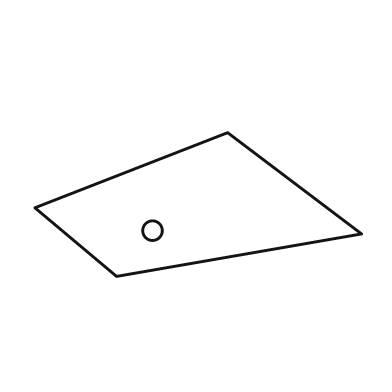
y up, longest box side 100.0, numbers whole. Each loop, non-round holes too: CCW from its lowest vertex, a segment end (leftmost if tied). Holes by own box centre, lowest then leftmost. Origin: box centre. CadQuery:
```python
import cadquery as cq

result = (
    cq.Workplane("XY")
    .moveTo(-25.0, -22.0)
    .lineTo(50.0, -9.0)
    .lineTo(9.0, 22.0)
    .lineTo(-50.0, -1.0)
    .close()
    .moveTo(-14.0, -8.0)
    .circle(3.0)
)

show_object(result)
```